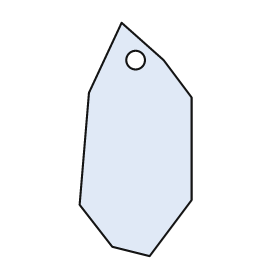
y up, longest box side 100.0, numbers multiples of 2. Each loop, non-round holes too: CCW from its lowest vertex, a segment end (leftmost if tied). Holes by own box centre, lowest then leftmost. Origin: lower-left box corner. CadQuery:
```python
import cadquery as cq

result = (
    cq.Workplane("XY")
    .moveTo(30.0, 0.0)
    .lineTo(48.0, 24.0)
    .lineTo(48.0, 68.0)
    .lineTo(36.0, 84.0)
    .lineTo(18.0, 100.0)
    .lineTo(4.0, 70.0)
    .lineTo(0.0, 22.0)
    .lineTo(14.0, 4.0)
    .close()
    .moveTo(24.0, 84.0)
    .circle(4.0)
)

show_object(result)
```